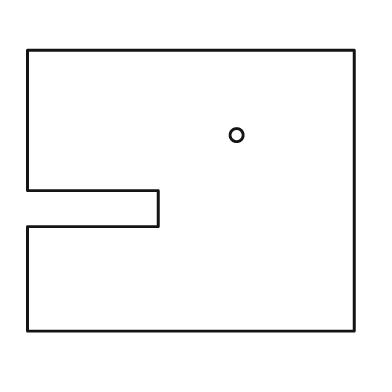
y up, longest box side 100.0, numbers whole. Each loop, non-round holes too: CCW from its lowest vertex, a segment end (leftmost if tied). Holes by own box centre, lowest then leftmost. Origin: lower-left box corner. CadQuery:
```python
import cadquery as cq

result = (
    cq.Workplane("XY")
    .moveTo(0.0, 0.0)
    .lineTo(100.0, 0.0)
    .lineTo(100.0, 86.0)
    .lineTo(0.0, 86.0)
    .lineTo(0.0, 43.0)
    .lineTo(40.0, 43.0)
    .lineTo(40.0, 32.0)
    .lineTo(0.0, 32.0)
    .close()
    .moveTo(64.0, 60.0)
    .circle(2.0)
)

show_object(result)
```